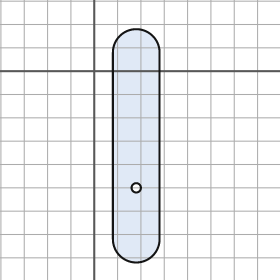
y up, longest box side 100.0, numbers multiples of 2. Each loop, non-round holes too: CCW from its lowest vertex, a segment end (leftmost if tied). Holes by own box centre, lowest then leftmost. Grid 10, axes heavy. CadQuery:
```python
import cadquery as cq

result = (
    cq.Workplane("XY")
    .moveTo(8.0, -72.0)
    .threePointArc((18.0, -82.0), (28.0, -72.0))
    .lineTo(28.0, 8.0)
    .threePointArc((18.0, 18.0), (8.0, 8.0))
    .close()
    .moveTo(18.0, -50.0)
    .circle(2.0)
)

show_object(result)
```